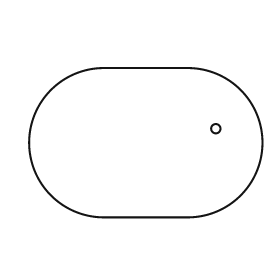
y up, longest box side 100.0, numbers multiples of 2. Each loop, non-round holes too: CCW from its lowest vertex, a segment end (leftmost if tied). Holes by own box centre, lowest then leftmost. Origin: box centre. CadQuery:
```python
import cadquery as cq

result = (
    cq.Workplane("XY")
    .moveTo(-18.0, -32.0)
    .lineTo(18.0, -32.0)
    .threePointArc((50.0, 0.0), (18.0, 32.0))
    .lineTo(-18.0, 32.0)
    .threePointArc((-50.0, 0.0), (-18.0, -32.0))
    .close()
    .moveTo(30.0, 6.0)
    .circle(2.0)
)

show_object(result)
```